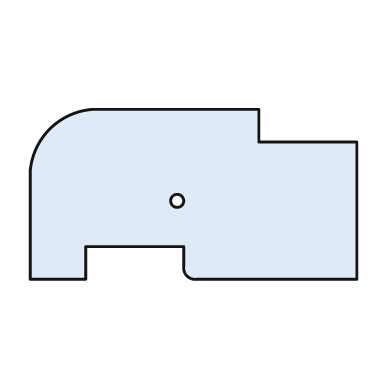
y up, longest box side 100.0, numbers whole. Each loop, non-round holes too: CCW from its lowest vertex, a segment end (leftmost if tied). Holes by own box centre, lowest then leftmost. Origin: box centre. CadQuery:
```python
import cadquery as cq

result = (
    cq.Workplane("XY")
    .moveTo(-50.0, -26.0)
    .lineTo(-33.0, -26.0)
    .lineTo(-33.0, -16.0)
    .lineTo(-3.0, -16.0)
    .lineTo(-3.0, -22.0)
    .threePointArc((-2.0, -25.0), (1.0, -26.0))
    .lineTo(50.0, -26.0)
    .lineTo(50.0, 16.0)
    .lineTo(20.0, 16.0)
    .lineTo(20.0, 26.0)
    .lineTo(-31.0, 26.0)
    .threePointArc((-44.0, 20.0), (-50.0, 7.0))
    .close()
    .moveTo(-5.0, -2.0)
    .circle(2.0)
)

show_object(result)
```